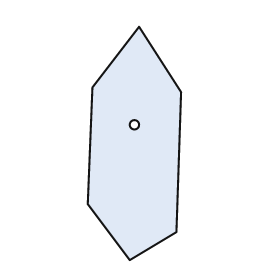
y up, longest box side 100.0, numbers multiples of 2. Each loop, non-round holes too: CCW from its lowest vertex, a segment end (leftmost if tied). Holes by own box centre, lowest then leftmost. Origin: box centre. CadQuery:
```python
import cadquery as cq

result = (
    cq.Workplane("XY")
    .moveTo(-2.0, -50.0)
    .lineTo(18.0, -38.0)
    .lineTo(20.0, 22.0)
    .lineTo(2.0, 50.0)
    .lineTo(-18.0, 24.0)
    .lineTo(-20.0, -26.0)
    .close()
    .moveTo(0.0, 8.0)
    .circle(2.0)
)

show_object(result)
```